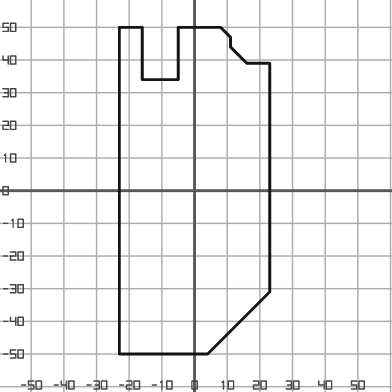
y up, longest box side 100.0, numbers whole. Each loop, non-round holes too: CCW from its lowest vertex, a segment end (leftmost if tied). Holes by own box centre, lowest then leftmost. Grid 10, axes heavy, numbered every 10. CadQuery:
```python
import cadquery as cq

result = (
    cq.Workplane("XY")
    .moveTo(-23.0, -50.0)
    .lineTo(4.0, -50.0)
    .lineTo(23.0, -31.0)
    .lineTo(23.0, 39.0)
    .lineTo(16.0, 39.0)
    .lineTo(11.0, 44.0)
    .lineTo(11.0, 47.0)
    .lineTo(8.0, 50.0)
    .lineTo(-5.0, 50.0)
    .lineTo(-5.0, 34.0)
    .lineTo(-16.0, 34.0)
    .lineTo(-16.0, 50.0)
    .lineTo(-23.0, 50.0)
    .close()
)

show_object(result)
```